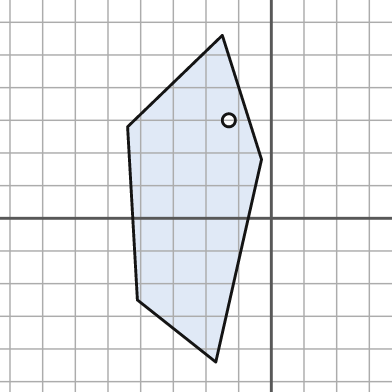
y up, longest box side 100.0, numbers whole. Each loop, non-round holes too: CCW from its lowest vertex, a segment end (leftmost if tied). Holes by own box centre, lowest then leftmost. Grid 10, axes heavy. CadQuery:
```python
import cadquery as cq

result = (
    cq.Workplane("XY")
    .moveTo(-17.0, -44.0)
    .lineTo(-3.0, 18.0)
    .lineTo(-15.0, 56.0)
    .lineTo(-44.0, 28.0)
    .lineTo(-41.0, -25.0)
    .close()
    .moveTo(-13.0, 30.0)
    .circle(2.0)
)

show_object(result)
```